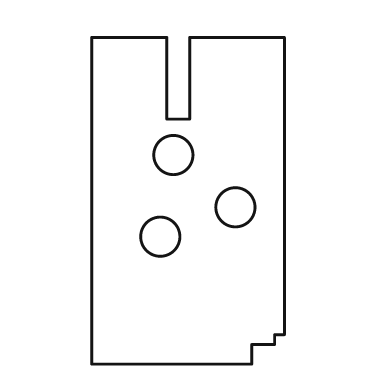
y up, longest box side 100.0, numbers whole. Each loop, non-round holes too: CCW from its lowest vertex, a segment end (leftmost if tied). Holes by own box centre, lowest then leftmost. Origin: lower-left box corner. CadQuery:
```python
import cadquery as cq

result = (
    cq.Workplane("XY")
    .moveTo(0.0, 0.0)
    .lineTo(49.0, 0.0)
    .lineTo(49.0, 6.0)
    .lineTo(56.0, 6.0)
    .lineTo(56.0, 9.0)
    .lineTo(59.0, 9.0)
    .lineTo(59.0, 100.0)
    .lineTo(30.0, 100.0)
    .lineTo(30.0, 75.0)
    .lineTo(23.0, 75.0)
    .lineTo(23.0, 100.0)
    .lineTo(0.0, 100.0)
    .close()
    .moveTo(21.0, 39.0)
    .circle(6.0)
    .moveTo(44.0, 48.0)
    .circle(6.0)
    .moveTo(25.0, 64.0)
    .circle(6.0)
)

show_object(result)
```